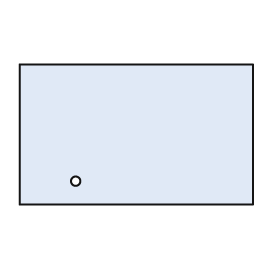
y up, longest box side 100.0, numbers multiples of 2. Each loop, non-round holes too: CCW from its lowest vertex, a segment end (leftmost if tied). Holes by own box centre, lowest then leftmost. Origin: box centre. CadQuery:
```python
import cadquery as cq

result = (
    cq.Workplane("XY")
    .moveTo(-50.0, -30.0)
    .lineTo(50.0, -30.0)
    .lineTo(50.0, 30.0)
    .lineTo(-50.0, 30.0)
    .close()
    .moveTo(-26.0, -20.0)
    .circle(2.0)
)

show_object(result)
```